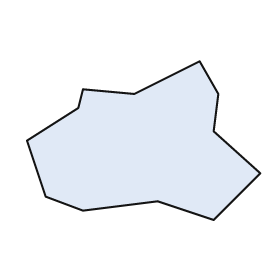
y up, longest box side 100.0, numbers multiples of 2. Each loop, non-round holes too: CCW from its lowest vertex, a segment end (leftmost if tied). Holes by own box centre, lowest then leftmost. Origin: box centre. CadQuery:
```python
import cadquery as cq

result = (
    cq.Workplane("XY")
    .moveTo(30.0, -34.0)
    .lineTo(50.0, -14.0)
    .lineTo(30.0, 4.0)
    .lineTo(32.0, 20.0)
    .lineTo(24.0, 34.0)
    .lineTo(-4.0, 20.0)
    .lineTo(-26.0, 22.0)
    .lineTo(-28.0, 14.0)
    .lineTo(-50.0, 0.0)
    .lineTo(-42.0, -24.0)
    .lineTo(-26.0, -30.0)
    .lineTo(6.0, -26.0)
    .close()
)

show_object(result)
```